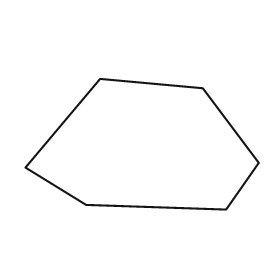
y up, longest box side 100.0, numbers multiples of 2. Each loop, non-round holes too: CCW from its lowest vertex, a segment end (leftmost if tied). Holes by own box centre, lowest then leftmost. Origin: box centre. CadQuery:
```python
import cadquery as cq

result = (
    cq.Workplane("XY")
    .moveTo(36.0, -28.0)
    .lineTo(50.0, -8.0)
    .lineTo(26.0, 24.0)
    .lineTo(-18.0, 28.0)
    .lineTo(-50.0, -10.0)
    .lineTo(-24.0, -26.0)
    .close()
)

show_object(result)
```